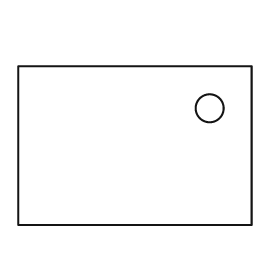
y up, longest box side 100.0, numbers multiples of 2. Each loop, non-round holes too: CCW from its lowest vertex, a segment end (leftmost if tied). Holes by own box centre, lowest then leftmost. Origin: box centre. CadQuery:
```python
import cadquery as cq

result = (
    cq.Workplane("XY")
    .moveTo(-50.0, -34.0)
    .lineTo(50.0, -34.0)
    .lineTo(50.0, 34.0)
    .lineTo(-50.0, 34.0)
    .close()
    .moveTo(32.0, 16.0)
    .circle(6.0)
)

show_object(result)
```